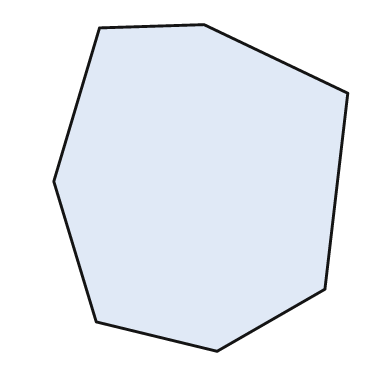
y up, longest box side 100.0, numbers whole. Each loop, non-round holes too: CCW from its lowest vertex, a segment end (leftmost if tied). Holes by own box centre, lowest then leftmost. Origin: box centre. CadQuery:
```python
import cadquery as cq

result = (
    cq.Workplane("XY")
    .moveTo(5.0, -50.0)
    .lineTo(38.0, -31.0)
    .lineTo(45.0, 29.0)
    .lineTo(1.0, 50.0)
    .lineTo(-31.0, 49.0)
    .lineTo(-45.0, 2.0)
    .lineTo(-32.0, -41.0)
    .close()
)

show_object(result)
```